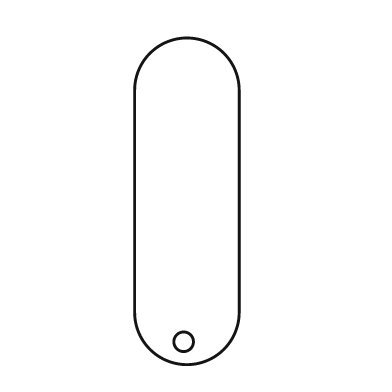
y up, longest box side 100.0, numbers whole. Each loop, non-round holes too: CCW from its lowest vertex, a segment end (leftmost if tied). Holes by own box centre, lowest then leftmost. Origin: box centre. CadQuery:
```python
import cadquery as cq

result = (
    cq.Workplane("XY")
    .moveTo(-16.0, -34.0)
    .threePointArc((0.0, -50.0), (16.0, -34.0))
    .lineTo(16.0, 34.0)
    .threePointArc((0.0, 50.0), (-16.0, 34.0))
    .close()
    .moveTo(-1.0, -43.0)
    .circle(3.0)
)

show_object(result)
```